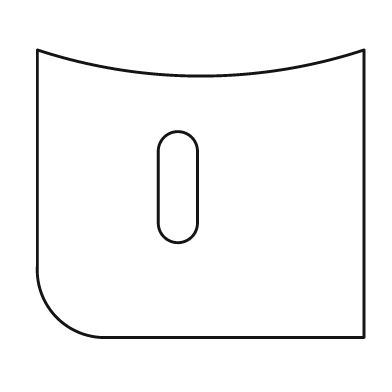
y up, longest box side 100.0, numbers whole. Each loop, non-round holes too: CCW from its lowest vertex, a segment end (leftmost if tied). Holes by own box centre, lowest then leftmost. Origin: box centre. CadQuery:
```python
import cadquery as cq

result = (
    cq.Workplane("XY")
    .moveTo(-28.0, -44.0)
    .lineTo(50.0, -44.0)
    .lineTo(50.0, 44.0)
    .threePointArc((0.0, 36.0), (-50.0, 44.0))
    .lineTo(-50.0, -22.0)
    .threePointArc((-44.0, -38.0), (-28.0, -44.0))
    .close()
    .moveTo(-13.0, -9.0)
    .threePointArc((-7.0, -15.0), (-1.0, -9.0))
    .lineTo(-1.0, 13.0)
    .threePointArc((-7.0, 19.0), (-13.0, 13.0))
    .close()
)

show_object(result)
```